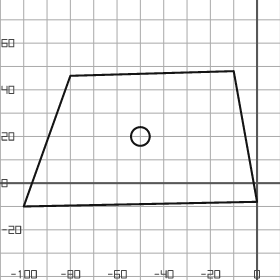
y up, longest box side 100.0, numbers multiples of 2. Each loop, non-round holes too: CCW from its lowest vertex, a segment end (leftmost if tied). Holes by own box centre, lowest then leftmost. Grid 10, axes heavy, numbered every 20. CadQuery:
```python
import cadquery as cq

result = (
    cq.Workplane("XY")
    .moveTo(-100.0, -10.0)
    .lineTo(0.0, -8.0)
    .lineTo(-10.0, 48.0)
    .lineTo(-80.0, 46.0)
    .close()
    .moveTo(-50.0, 20.0)
    .circle(4.0)
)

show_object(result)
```